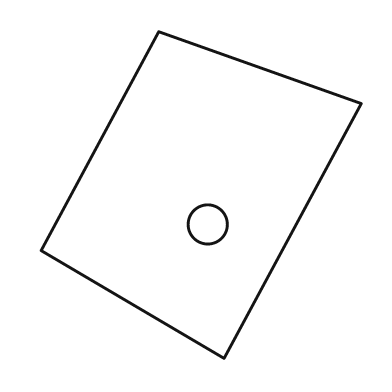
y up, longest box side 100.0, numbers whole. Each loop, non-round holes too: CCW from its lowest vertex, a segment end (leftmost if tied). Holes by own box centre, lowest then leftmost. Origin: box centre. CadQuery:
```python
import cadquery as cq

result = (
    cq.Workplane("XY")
    .moveTo(7.0, -50.0)
    .lineTo(49.0, 28.0)
    .lineTo(-13.0, 50.0)
    .lineTo(-49.0, -17.0)
    .close()
    .moveTo(2.0, -9.0)
    .circle(6.0)
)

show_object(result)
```